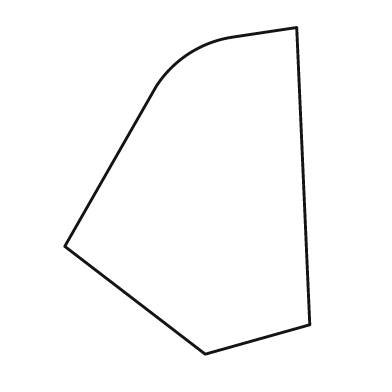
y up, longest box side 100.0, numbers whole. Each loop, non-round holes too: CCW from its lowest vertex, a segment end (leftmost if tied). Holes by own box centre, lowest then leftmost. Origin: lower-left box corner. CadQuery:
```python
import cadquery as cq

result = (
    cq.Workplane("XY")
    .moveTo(43.0, 0.0)
    .lineTo(75.0, 9.0)
    .lineTo(71.0, 100.0)
    .lineTo(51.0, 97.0)
    .threePointArc((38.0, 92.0), (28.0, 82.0))
    .lineTo(0.0, 33.0)
    .close()
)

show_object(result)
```